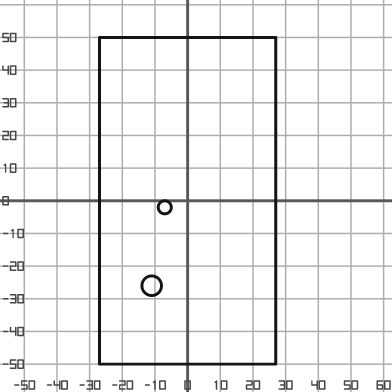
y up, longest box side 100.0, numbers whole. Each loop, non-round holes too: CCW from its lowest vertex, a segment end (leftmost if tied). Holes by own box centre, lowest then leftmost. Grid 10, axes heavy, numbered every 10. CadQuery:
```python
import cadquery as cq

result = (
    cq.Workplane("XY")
    .moveTo(-27.0, -50.0)
    .lineTo(27.0, -50.0)
    .lineTo(27.0, 50.0)
    .lineTo(-27.0, 50.0)
    .close()
    .moveTo(-11.0, -26.0)
    .circle(3.0)
    .moveTo(-7.0, -2.0)
    .circle(2.0)
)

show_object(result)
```